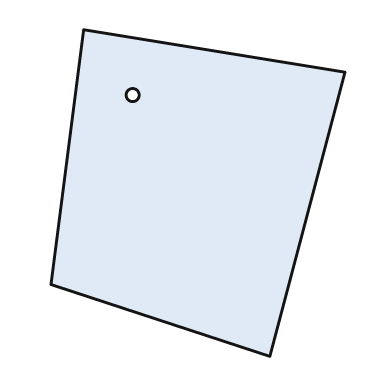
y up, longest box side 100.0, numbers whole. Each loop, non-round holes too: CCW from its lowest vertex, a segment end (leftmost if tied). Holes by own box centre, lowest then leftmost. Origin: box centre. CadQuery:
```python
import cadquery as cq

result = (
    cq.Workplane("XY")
    .moveTo(22.0, -50.0)
    .lineTo(45.0, 37.0)
    .lineTo(-35.0, 50.0)
    .lineTo(-45.0, -28.0)
    .close()
    .moveTo(-20.0, 30.0)
    .circle(2.0)
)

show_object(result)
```